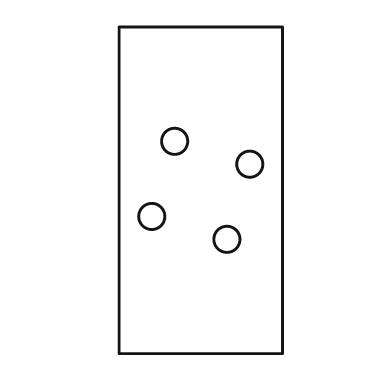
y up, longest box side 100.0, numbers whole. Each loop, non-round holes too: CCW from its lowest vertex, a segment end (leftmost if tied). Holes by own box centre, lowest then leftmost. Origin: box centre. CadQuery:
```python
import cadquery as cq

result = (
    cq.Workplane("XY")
    .moveTo(-25.0, -50.0)
    .lineTo(25.0, -50.0)
    .lineTo(25.0, 50.0)
    .lineTo(-25.0, 50.0)
    .close()
    .moveTo(8.0, -15.0)
    .circle(4.0)
    .moveTo(-15.0, -8.0)
    .circle(4.0)
    .moveTo(15.0, 8.0)
    .circle(4.0)
    .moveTo(-8.0, 15.0)
    .circle(4.0)
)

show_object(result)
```